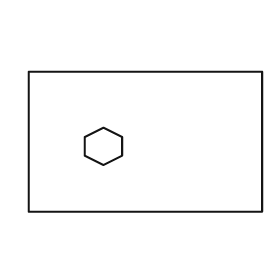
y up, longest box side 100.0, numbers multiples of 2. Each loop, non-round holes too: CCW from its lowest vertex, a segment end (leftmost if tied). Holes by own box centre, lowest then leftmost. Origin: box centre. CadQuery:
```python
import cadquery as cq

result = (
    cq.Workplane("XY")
    .moveTo(-50.0, -30.0)
    .lineTo(50.0, -30.0)
    .lineTo(50.0, 30.0)
    .lineTo(-50.0, 30.0)
    .close()
    .moveTo(-18.0, -10.0)
    .lineTo(-10.0, -6.0)
    .lineTo(-10.0, 2.0)
    .lineTo(-18.0, 6.0)
    .lineTo(-26.0, 2.0)
    .lineTo(-26.0, -6.0)
    .close()
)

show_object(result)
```